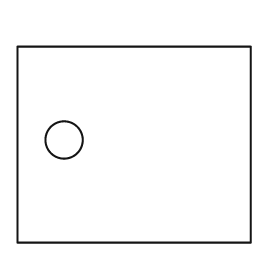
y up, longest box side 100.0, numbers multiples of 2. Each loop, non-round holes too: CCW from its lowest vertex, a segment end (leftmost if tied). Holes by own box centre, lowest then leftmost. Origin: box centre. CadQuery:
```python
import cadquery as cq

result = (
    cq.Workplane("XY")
    .moveTo(-50.0, -42.0)
    .lineTo(50.0, -42.0)
    .lineTo(50.0, 42.0)
    .lineTo(-50.0, 42.0)
    .close()
    .moveTo(-30.0, 2.0)
    .circle(8.0)
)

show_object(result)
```